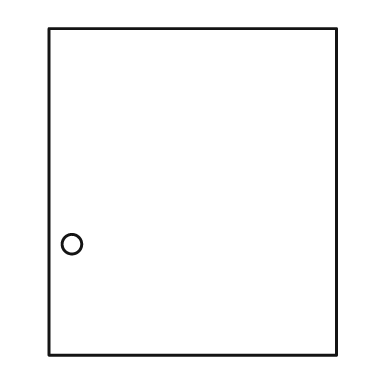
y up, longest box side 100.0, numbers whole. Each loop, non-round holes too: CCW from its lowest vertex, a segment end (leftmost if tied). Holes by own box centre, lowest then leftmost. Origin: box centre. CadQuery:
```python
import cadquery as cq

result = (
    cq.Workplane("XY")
    .moveTo(-44.0, -50.0)
    .lineTo(44.0, -50.0)
    .lineTo(44.0, 50.0)
    .lineTo(-44.0, 50.0)
    .close()
    .moveTo(-37.0, -16.0)
    .circle(3.0)
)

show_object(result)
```